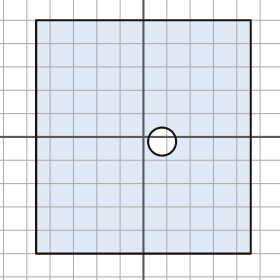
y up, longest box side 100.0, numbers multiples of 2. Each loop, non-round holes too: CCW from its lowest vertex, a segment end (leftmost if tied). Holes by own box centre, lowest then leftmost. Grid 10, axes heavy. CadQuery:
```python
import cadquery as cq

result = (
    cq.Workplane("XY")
    .moveTo(-46.0, -50.0)
    .lineTo(46.0, -50.0)
    .lineTo(46.0, 50.0)
    .lineTo(-46.0, 50.0)
    .close()
    .moveTo(8.0, -2.0)
    .circle(6.0)
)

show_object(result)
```